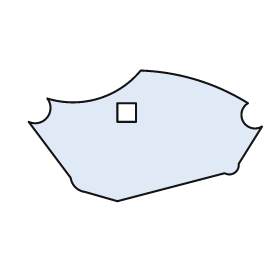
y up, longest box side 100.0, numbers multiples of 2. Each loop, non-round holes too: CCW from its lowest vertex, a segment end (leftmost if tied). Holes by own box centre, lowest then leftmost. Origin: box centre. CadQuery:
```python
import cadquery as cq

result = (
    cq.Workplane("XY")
    .moveTo(-12.0, -28.0)
    .lineTo(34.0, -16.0)
    .threePointArc((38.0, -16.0), (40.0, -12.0))
    .lineTo(50.0, 4.0)
    .threePointArc((42.0, 6.0), (44.0, 14.0))
    .threePointArc((22.0, 24.0), (-2.0, 28.0))
    .threePointArc((-20.0, 16.0), (-42.0, 16.0))
    .threePointArc((-42.0, 8.0), (-50.0, 6.0))
    .lineTo(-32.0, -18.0)
    .threePointArc((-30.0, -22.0), (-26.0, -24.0))
    .close()
    .moveTo(-12.0, 6.0)
    .lineTo(-4.0, 6.0)
    .lineTo(-4.0, 14.0)
    .lineTo(-12.0, 14.0)
    .close()
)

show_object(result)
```